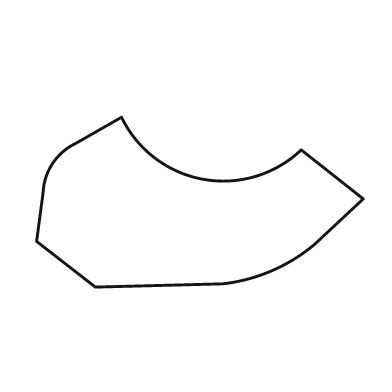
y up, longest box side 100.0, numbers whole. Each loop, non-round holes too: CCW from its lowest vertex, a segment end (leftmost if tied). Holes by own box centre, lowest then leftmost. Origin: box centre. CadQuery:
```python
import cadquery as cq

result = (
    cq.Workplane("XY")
    .moveTo(-32.0, -26.0)
    .lineTo(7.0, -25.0)
    .threePointArc((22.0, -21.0), (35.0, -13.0))
    .lineTo(50.0, 1.0)
    .lineTo(31.0, 16.0)
    .threePointArc((1.0, 7.0), (-24.0, 26.0))
    .lineTo(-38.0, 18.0)
    .threePointArc((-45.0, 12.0), (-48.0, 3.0))
    .lineTo(-50.0, -12.0)
    .close()
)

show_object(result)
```